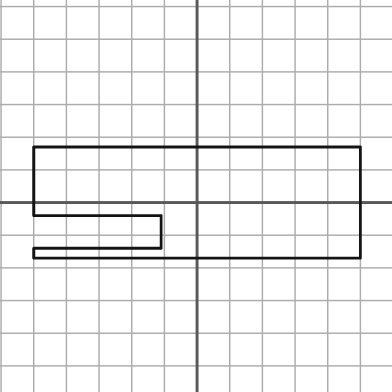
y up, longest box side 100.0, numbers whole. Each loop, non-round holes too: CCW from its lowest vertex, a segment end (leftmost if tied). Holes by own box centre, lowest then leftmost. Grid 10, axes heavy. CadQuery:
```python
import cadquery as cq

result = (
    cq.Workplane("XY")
    .moveTo(-50.0, -17.0)
    .lineTo(50.0, -17.0)
    .lineTo(50.0, 17.0)
    .lineTo(-50.0, 17.0)
    .lineTo(-50.0, -4.0)
    .lineTo(-11.0, -4.0)
    .lineTo(-11.0, -14.0)
    .lineTo(-50.0, -14.0)
    .close()
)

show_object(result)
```